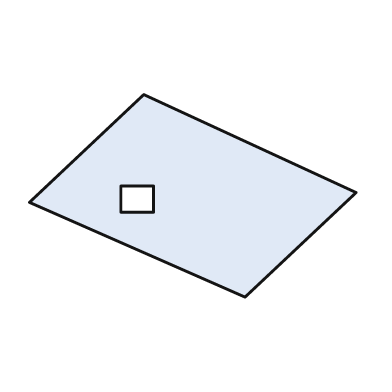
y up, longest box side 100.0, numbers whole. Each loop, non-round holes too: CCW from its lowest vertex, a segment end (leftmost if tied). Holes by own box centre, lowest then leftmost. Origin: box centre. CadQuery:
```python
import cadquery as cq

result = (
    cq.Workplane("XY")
    .moveTo(16.0, -31.0)
    .lineTo(50.0, 1.0)
    .lineTo(-15.0, 31.0)
    .lineTo(-50.0, -2.0)
    .close()
    .moveTo(-22.0, -5.0)
    .lineTo(-12.0, -5.0)
    .lineTo(-12.0, 3.0)
    .lineTo(-22.0, 3.0)
    .close()
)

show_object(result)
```